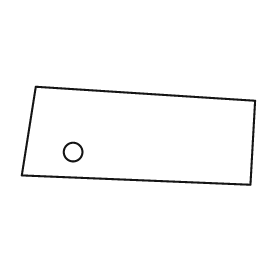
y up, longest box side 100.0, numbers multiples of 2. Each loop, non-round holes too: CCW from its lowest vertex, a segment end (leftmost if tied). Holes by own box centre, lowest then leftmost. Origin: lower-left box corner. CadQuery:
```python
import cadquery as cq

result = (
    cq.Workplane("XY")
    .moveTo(98.0, 0.0)
    .lineTo(100.0, 36.0)
    .lineTo(6.0, 42.0)
    .lineTo(0.0, 4.0)
    .close()
    .moveTo(22.0, 14.0)
    .circle(4.0)
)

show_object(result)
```